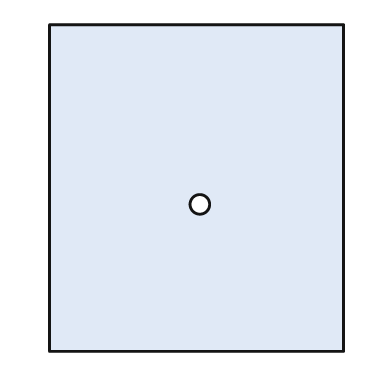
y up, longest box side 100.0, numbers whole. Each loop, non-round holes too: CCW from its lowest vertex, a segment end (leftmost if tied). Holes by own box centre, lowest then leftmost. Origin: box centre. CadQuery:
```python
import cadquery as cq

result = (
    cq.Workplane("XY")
    .moveTo(-45.0, -50.0)
    .lineTo(45.0, -50.0)
    .lineTo(45.0, 50.0)
    .lineTo(-45.0, 50.0)
    .close()
    .moveTo(1.0, -5.0)
    .circle(3.0)
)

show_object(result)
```